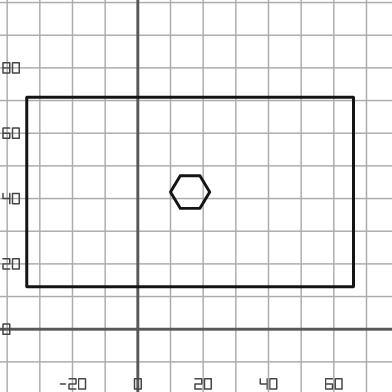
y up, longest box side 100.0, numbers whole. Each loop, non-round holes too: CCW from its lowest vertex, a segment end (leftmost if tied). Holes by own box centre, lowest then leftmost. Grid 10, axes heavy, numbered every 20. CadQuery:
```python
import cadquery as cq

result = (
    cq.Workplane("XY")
    .moveTo(-34.0, 13.0)
    .lineTo(66.0, 13.0)
    .lineTo(66.0, 71.0)
    .lineTo(-34.0, 71.0)
    .close()
    .moveTo(13.0, 37.0)
    .lineTo(19.0, 37.0)
    .lineTo(22.0, 42.0)
    .lineTo(19.0, 47.0)
    .lineTo(13.0, 47.0)
    .lineTo(10.0, 42.0)
    .close()
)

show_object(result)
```